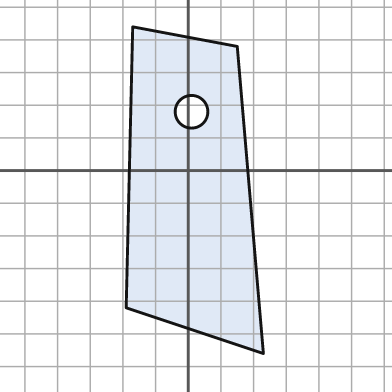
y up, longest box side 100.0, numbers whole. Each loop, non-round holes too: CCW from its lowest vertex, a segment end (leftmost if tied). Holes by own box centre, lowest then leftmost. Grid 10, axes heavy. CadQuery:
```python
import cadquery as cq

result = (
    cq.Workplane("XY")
    .moveTo(23.0, -56.0)
    .lineTo(15.0, 38.0)
    .lineTo(-17.0, 44.0)
    .lineTo(-19.0, -42.0)
    .close()
    .moveTo(1.0, 18.0)
    .circle(5.0)
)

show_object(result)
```